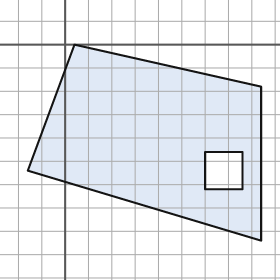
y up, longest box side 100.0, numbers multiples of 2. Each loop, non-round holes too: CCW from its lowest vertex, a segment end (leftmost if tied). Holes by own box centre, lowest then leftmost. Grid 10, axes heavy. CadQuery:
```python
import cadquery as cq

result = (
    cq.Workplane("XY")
    .moveTo(84.0, -84.0)
    .lineTo(84.0, -18.0)
    .lineTo(4.0, 0.0)
    .lineTo(-16.0, -54.0)
    .close()
    .moveTo(60.0, -62.0)
    .lineTo(76.0, -62.0)
    .lineTo(76.0, -46.0)
    .lineTo(60.0, -46.0)
    .close()
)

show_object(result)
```